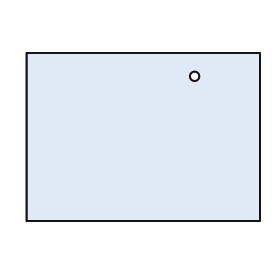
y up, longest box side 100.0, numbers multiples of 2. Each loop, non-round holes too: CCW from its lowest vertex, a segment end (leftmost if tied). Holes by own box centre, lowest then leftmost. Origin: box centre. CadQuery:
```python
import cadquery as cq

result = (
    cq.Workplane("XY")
    .moveTo(-50.0, -36.0)
    .lineTo(50.0, -36.0)
    .lineTo(50.0, 36.0)
    .lineTo(-50.0, 36.0)
    .close()
    .moveTo(22.0, 26.0)
    .circle(2.0)
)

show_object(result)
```